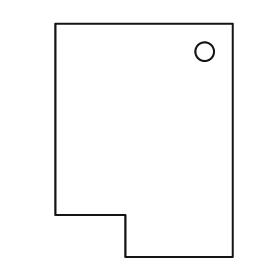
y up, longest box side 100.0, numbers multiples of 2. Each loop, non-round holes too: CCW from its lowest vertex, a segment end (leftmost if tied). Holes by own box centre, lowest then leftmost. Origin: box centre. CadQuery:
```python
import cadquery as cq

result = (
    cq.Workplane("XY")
    .moveTo(-8.0, -50.0)
    .lineTo(38.0, -50.0)
    .lineTo(38.0, 50.0)
    .lineTo(-38.0, 50.0)
    .lineTo(-38.0, -32.0)
    .lineTo(-8.0, -32.0)
    .close()
    .moveTo(26.0, 38.0)
    .circle(4.0)
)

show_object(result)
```